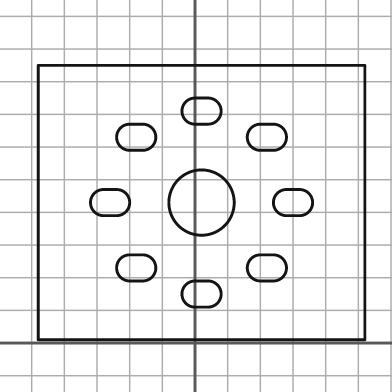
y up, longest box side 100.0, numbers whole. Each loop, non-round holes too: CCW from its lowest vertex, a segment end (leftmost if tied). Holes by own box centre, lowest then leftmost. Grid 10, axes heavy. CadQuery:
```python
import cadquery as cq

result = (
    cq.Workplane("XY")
    .moveTo(-48.0, 1.0)
    .lineTo(52.0, 1.0)
    .lineTo(52.0, 85.0)
    .lineTo(-48.0, 85.0)
    .close()
    .moveTo(0.0, 11.0)
    .lineTo(4.0, 11.0)
    .threePointArc((8.0, 15.0), (4.0, 19.0))
    .lineTo(0.0, 19.0)
    .threePointArc((-4.0, 15.0), (0.0, 11.0))
    .close()
    .moveTo(-20.0, 19.0)
    .lineTo(-16.0, 19.0)
    .threePointArc((-12.0, 23.0), (-16.0, 27.0))
    .lineTo(-20.0, 27.0)
    .threePointArc((-24.0, 23.0), (-20.0, 19.0))
    .close()
    .moveTo(20.0, 19.0)
    .lineTo(24.0, 19.0)
    .threePointArc((28.0, 23.0), (24.0, 27.0))
    .lineTo(20.0, 27.0)
    .threePointArc((16.0, 23.0), (20.0, 19.0))
    .close()
    .moveTo(-28.0, 39.0)
    .lineTo(-24.0, 39.0)
    .threePointArc((-20.0, 43.0), (-24.0, 47.0))
    .lineTo(-28.0, 47.0)
    .threePointArc((-32.0, 43.0), (-28.0, 39.0))
    .close()
    .moveTo(2.0, 43.0)
    .circle(10.0)
    .moveTo(28.0, 39.0)
    .lineTo(32.0, 39.0)
    .threePointArc((36.0, 43.0), (32.0, 47.0))
    .lineTo(28.0, 47.0)
    .threePointArc((24.0, 43.0), (28.0, 39.0))
    .close()
    .moveTo(-20.0, 59.0)
    .lineTo(-16.0, 59.0)
    .threePointArc((-12.0, 63.0), (-16.0, 67.0))
    .lineTo(-20.0, 67.0)
    .threePointArc((-24.0, 63.0), (-20.0, 59.0))
    .close()
    .moveTo(20.0, 59.0)
    .lineTo(24.0, 59.0)
    .threePointArc((28.0, 63.0), (24.0, 67.0))
    .lineTo(20.0, 67.0)
    .threePointArc((16.0, 63.0), (20.0, 59.0))
    .close()
    .moveTo(0.0, 67.0)
    .lineTo(4.0, 67.0)
    .threePointArc((8.0, 71.0), (4.0, 75.0))
    .lineTo(0.0, 75.0)
    .threePointArc((-4.0, 71.0), (0.0, 67.0))
    .close()
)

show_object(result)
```